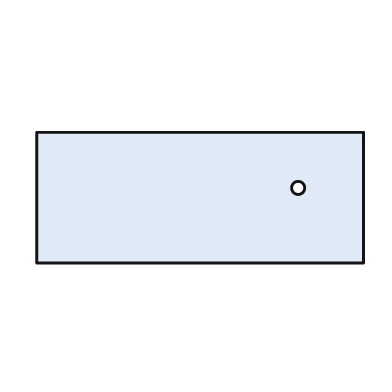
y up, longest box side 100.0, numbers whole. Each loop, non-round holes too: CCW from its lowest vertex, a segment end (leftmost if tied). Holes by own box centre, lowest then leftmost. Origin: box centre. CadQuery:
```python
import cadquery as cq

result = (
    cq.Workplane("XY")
    .moveTo(-50.0, -20.0)
    .lineTo(50.0, -20.0)
    .lineTo(50.0, 20.0)
    .lineTo(-50.0, 20.0)
    .close()
    .moveTo(30.0, 3.0)
    .circle(2.0)
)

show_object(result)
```